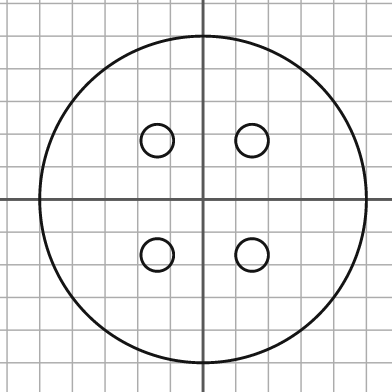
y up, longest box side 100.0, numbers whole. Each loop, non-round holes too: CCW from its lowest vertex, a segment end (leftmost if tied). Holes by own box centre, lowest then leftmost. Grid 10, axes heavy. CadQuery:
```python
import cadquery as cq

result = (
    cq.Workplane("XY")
    .moveTo(0.0, 0.0)
    .circle(50.0)
    .moveTo(-14.0, -17.0)
    .circle(5.0)
    .moveTo(15.0, -17.0)
    .circle(5.0)
    .moveTo(-14.0, 18.0)
    .circle(5.0)
    .moveTo(15.0, 18.0)
    .circle(5.0)
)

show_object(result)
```